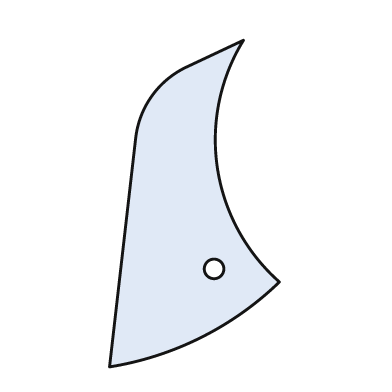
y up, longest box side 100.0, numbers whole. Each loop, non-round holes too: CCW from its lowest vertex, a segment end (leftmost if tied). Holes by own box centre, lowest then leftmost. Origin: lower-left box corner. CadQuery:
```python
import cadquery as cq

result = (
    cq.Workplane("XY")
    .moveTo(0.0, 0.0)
    .threePointArc((28.0, 9.0), (52.0, 26.0))
    .threePointArc((33.0, 61.0), (41.0, 100.0))
    .lineTo(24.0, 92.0)
    .threePointArc((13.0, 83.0), (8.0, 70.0))
    .close()
    .moveTo(32.0, 30.0)
    .circle(3.0)
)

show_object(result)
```